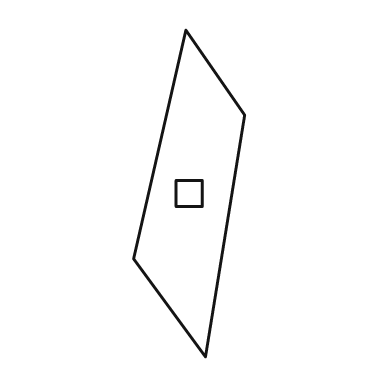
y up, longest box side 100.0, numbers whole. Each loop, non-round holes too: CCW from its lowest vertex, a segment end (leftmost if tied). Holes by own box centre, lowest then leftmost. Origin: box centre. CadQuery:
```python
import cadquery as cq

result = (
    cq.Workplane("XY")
    .moveTo(5.0, -50.0)
    .lineTo(17.0, 24.0)
    .lineTo(-1.0, 50.0)
    .lineTo(-17.0, -20.0)
    .close()
    .moveTo(-4.0, -4.0)
    .lineTo(4.0, -4.0)
    .lineTo(4.0, 4.0)
    .lineTo(-4.0, 4.0)
    .close()
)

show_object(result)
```